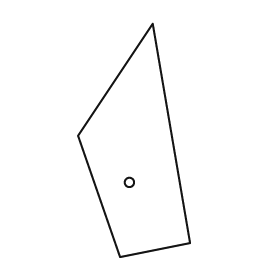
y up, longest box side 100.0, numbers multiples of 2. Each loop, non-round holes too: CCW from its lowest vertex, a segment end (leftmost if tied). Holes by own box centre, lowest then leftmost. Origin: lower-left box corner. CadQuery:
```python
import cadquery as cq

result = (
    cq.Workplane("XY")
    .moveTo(18.0, 0.0)
    .lineTo(48.0, 6.0)
    .lineTo(32.0, 100.0)
    .lineTo(0.0, 52.0)
    .close()
    .moveTo(22.0, 32.0)
    .circle(2.0)
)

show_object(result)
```